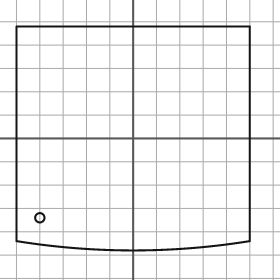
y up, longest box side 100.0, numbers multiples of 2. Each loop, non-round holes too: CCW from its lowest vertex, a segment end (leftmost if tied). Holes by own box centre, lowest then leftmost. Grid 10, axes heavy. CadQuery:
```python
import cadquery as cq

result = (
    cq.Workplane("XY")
    .moveTo(-50.0, -44.0)
    .threePointArc((0.0, -48.0), (50.0, -44.0))
    .lineTo(50.0, 48.0)
    .lineTo(-50.0, 48.0)
    .close()
    .moveTo(-40.0, -34.0)
    .circle(2.0)
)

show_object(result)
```